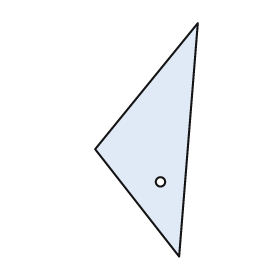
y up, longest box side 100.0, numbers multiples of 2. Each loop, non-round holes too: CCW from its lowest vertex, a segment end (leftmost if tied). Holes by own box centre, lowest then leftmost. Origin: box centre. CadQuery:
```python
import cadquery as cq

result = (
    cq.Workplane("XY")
    .moveTo(14.0, -50.0)
    .lineTo(22.0, 50.0)
    .lineTo(-22.0, -4.0)
    .close()
    .moveTo(6.0, -18.0)
    .circle(2.0)
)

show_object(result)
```